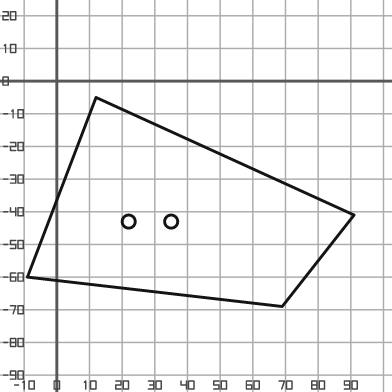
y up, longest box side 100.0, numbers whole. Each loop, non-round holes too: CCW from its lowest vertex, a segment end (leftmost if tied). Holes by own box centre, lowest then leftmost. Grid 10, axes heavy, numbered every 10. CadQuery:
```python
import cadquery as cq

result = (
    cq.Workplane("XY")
    .moveTo(69.0, -69.0)
    .lineTo(91.0, -41.0)
    .lineTo(12.0, -5.0)
    .lineTo(-9.0, -60.0)
    .close()
    .moveTo(22.0, -43.0)
    .circle(2.0)
    .moveTo(35.0, -43.0)
    .circle(2.0)
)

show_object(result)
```